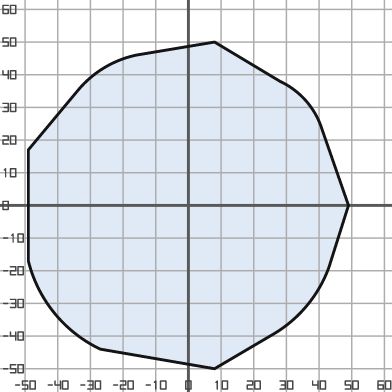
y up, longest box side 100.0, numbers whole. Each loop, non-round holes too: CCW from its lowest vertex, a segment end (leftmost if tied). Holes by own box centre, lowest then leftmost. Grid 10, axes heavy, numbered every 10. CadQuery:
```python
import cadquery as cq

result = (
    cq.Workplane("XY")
    .moveTo(8.0, -50.0)
    .lineTo(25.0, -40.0)
    .threePointArc((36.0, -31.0), (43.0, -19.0))
    .lineTo(49.0, 0.0)
    .lineTo(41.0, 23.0)
    .threePointArc((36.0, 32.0), (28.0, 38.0))
    .lineTo(8.0, 50.0)
    .lineTo(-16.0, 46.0)
    .threePointArc((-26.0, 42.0), (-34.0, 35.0))
    .lineTo(-49.0, 17.0)
    .lineTo(-49.0, -17.0)
    .threePointArc((-41.0, -33.0), (-27.0, -44.0))
    .close()
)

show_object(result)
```